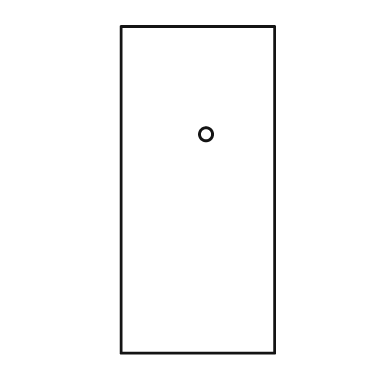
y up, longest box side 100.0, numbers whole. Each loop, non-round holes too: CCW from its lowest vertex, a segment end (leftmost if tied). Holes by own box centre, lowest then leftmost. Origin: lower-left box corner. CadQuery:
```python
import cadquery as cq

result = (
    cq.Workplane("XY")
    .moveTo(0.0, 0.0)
    .lineTo(47.0, 0.0)
    .lineTo(47.0, 100.0)
    .lineTo(0.0, 100.0)
    .close()
    .moveTo(26.0, 67.0)
    .circle(2.0)
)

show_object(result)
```